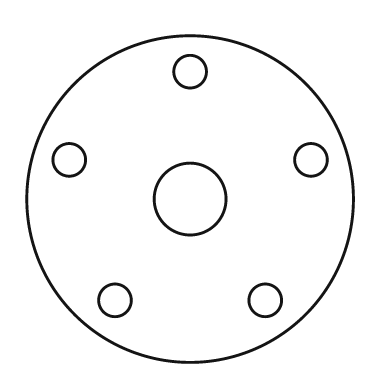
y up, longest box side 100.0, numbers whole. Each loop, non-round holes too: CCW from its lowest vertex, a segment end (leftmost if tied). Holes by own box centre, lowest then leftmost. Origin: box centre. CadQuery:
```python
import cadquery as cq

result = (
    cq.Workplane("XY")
    .moveTo(0.0, 0.0)
    .circle(50.0)
    .moveTo(-23.0, -31.0)
    .circle(5.0)
    .moveTo(23.0, -31.0)
    .circle(5.0)
    .moveTo(0.0, 0.0)
    .circle(11.0)
    .moveTo(-37.0, 12.0)
    .circle(5.0)
    .moveTo(37.0, 12.0)
    .circle(5.0)
    .moveTo(0.0, 39.0)
    .circle(5.0)
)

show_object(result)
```